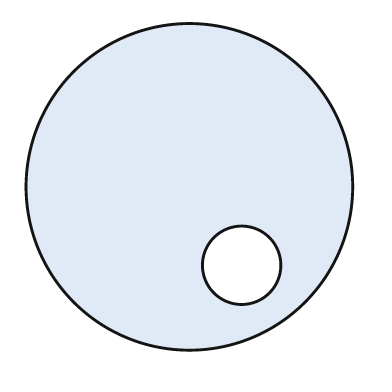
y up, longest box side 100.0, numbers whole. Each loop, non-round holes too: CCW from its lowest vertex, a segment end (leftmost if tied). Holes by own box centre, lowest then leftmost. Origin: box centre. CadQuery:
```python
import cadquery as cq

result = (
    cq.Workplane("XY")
    .moveTo(0.0, 0.0)
    .circle(50.0)
    .moveTo(16.0, -24.0)
    .circle(12.0)
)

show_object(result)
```